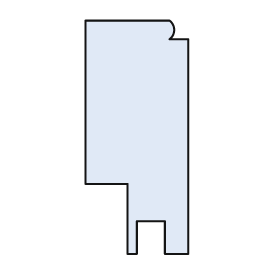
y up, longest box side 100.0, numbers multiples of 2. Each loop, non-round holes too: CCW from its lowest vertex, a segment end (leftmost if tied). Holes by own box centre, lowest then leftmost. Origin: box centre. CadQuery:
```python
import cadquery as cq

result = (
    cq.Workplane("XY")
    .moveTo(-4.0, -50.0)
    .lineTo(0.0, -50.0)
    .lineTo(0.0, -36.0)
    .lineTo(12.0, -36.0)
    .lineTo(12.0, -50.0)
    .lineTo(22.0, -50.0)
    .lineTo(22.0, 42.0)
    .lineTo(14.0, 42.0)
    .threePointArc((16.0, 46.0), (14.0, 50.0))
    .lineTo(-22.0, 50.0)
    .lineTo(-22.0, -20.0)
    .lineTo(-4.0, -20.0)
    .close()
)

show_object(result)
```